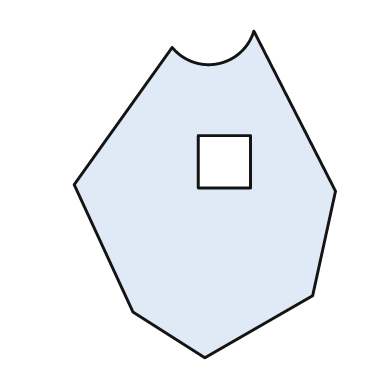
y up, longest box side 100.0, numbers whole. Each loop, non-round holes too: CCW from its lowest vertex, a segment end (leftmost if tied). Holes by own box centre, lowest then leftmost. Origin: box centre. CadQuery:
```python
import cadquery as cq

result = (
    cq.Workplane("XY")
    .moveTo(0.0, -50.0)
    .lineTo(33.0, -31.0)
    .lineTo(40.0, 1.0)
    .lineTo(15.0, 50.0)
    .threePointArc((4.0, 40.0), (-10.0, 45.0))
    .lineTo(-40.0, 3.0)
    .lineTo(-22.0, -36.0)
    .close()
    .moveTo(-2.0, 2.0)
    .lineTo(14.0, 2.0)
    .lineTo(14.0, 18.0)
    .lineTo(-2.0, 18.0)
    .close()
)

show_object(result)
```